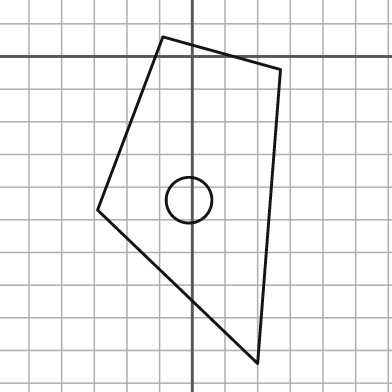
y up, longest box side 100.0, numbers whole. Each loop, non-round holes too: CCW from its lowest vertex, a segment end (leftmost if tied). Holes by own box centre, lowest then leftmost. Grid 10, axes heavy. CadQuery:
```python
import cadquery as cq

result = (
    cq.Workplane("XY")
    .moveTo(20.0, -94.0)
    .lineTo(27.0, -4.0)
    .lineTo(-9.0, 6.0)
    .lineTo(-29.0, -47.0)
    .close()
    .moveTo(-1.0, -44.0)
    .circle(7.0)
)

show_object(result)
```